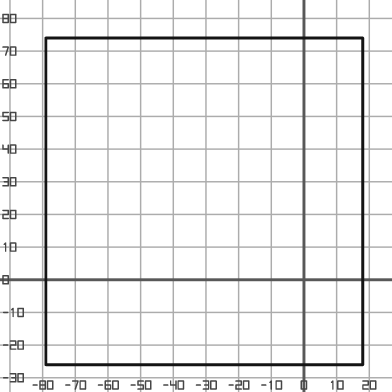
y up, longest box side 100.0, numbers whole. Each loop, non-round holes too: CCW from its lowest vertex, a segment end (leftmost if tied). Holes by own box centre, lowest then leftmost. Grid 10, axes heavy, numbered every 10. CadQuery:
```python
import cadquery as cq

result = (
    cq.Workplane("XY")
    .moveTo(-79.0, -26.0)
    .lineTo(18.0, -26.0)
    .lineTo(18.0, 74.0)
    .lineTo(-79.0, 74.0)
    .close()
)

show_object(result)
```